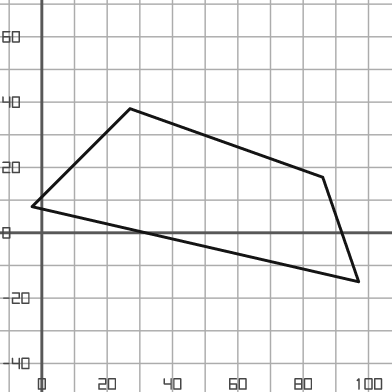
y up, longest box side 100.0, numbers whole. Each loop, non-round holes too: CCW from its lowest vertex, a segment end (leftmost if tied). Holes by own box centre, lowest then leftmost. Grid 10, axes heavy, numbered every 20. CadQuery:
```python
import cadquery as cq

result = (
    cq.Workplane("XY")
    .moveTo(97.0, -15.0)
    .lineTo(86.0, 17.0)
    .lineTo(27.0, 38.0)
    .lineTo(-3.0, 8.0)
    .close()
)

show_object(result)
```